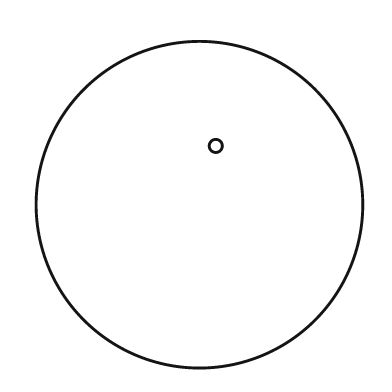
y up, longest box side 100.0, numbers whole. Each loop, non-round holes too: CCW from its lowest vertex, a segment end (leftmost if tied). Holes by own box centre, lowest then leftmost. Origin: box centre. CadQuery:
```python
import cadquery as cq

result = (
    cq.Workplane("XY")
    .moveTo(0.0, 0.0)
    .circle(50.0)
    .moveTo(5.0, 18.0)
    .circle(2.0)
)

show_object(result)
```